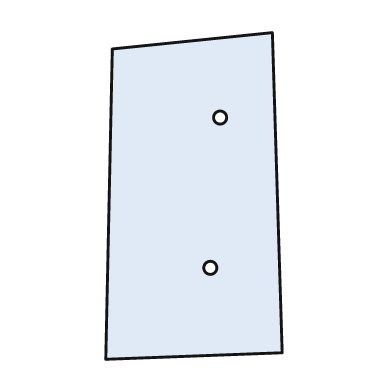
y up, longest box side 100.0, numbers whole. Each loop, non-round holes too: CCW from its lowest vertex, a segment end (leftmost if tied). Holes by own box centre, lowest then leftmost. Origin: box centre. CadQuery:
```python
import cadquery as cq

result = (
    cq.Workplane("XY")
    .moveTo(-27.0, -50.0)
    .lineTo(27.0, -48.0)
    .lineTo(24.0, 50.0)
    .lineTo(-25.0, 45.0)
    .close()
    .moveTo(5.0, -22.0)
    .circle(2.0)
    .moveTo(8.0, 24.0)
    .circle(2.0)
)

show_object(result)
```